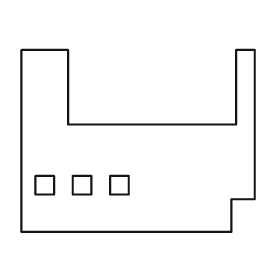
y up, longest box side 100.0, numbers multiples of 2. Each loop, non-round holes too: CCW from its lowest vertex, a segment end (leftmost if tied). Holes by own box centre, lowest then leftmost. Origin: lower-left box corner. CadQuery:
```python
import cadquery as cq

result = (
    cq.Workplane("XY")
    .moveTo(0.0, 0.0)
    .lineTo(90.0, 0.0)
    .lineTo(90.0, 14.0)
    .lineTo(100.0, 14.0)
    .lineTo(100.0, 78.0)
    .lineTo(92.0, 78.0)
    .lineTo(92.0, 46.0)
    .lineTo(20.0, 46.0)
    .lineTo(20.0, 78.0)
    .lineTo(0.0, 78.0)
    .close()
    .moveTo(6.0, 16.0)
    .lineTo(14.0, 16.0)
    .lineTo(14.0, 24.0)
    .lineTo(6.0, 24.0)
    .close()
    .moveTo(22.0, 16.0)
    .lineTo(30.0, 16.0)
    .lineTo(30.0, 24.0)
    .lineTo(22.0, 24.0)
    .close()
    .moveTo(38.0, 16.0)
    .lineTo(46.0, 16.0)
    .lineTo(46.0, 24.0)
    .lineTo(38.0, 24.0)
    .close()
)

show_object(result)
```